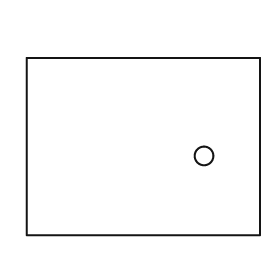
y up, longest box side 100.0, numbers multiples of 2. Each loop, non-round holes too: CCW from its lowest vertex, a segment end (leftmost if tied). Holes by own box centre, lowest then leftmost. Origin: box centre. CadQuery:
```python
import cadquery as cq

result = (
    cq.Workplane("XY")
    .moveTo(-50.0, -38.0)
    .lineTo(50.0, -38.0)
    .lineTo(50.0, 38.0)
    .lineTo(-50.0, 38.0)
    .close()
    .moveTo(26.0, -4.0)
    .circle(4.0)
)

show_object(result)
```